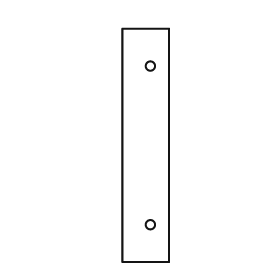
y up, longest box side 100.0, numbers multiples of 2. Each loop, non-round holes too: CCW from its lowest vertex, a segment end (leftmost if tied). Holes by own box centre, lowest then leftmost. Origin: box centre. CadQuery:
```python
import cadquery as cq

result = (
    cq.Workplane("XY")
    .moveTo(-10.0, -50.0)
    .lineTo(10.0, -50.0)
    .lineTo(10.0, 50.0)
    .lineTo(-10.0, 50.0)
    .close()
    .moveTo(2.0, -34.0)
    .circle(2.0)
    .moveTo(2.0, 34.0)
    .circle(2.0)
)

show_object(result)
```